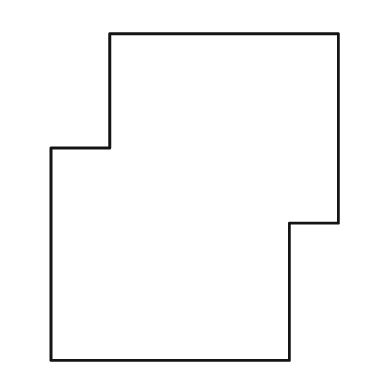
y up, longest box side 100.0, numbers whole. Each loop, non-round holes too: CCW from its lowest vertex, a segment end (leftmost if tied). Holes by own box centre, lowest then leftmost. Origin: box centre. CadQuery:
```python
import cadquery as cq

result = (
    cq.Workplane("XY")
    .moveTo(-44.0, -50.0)
    .lineTo(29.0, -50.0)
    .lineTo(29.0, -8.0)
    .lineTo(44.0, -8.0)
    .lineTo(44.0, 50.0)
    .lineTo(-26.0, 50.0)
    .lineTo(-26.0, 15.0)
    .lineTo(-44.0, 15.0)
    .close()
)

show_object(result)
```